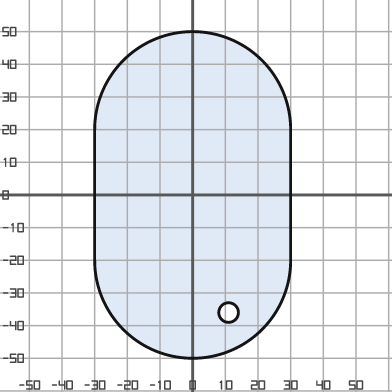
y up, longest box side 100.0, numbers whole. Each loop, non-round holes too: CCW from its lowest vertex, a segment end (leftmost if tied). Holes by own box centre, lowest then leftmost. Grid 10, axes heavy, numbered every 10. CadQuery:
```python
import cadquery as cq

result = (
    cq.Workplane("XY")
    .moveTo(-30.0, -20.0)
    .threePointArc((0.0, -50.0), (30.0, -20.0))
    .lineTo(30.0, 20.0)
    .threePointArc((0.0, 50.0), (-30.0, 20.0))
    .close()
    .moveTo(11.0, -36.0)
    .circle(3.0)
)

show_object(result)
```